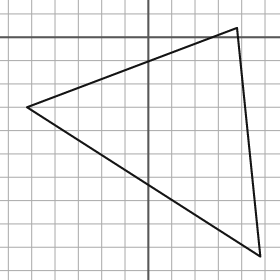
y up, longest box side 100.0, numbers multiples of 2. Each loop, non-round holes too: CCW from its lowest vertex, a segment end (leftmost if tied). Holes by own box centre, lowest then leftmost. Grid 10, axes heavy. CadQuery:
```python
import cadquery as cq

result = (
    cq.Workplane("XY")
    .moveTo(48.0, -94.0)
    .lineTo(38.0, 4.0)
    .lineTo(-52.0, -30.0)
    .close()
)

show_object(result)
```